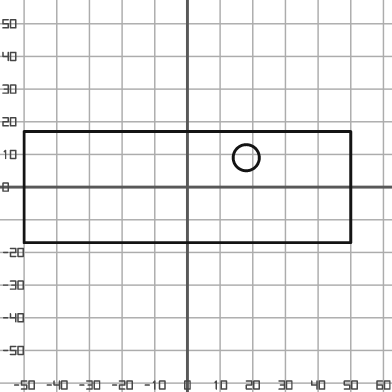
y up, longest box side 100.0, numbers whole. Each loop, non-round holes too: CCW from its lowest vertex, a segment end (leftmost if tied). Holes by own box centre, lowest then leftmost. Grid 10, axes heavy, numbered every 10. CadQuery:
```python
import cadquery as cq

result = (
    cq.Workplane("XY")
    .moveTo(-50.0, -17.0)
    .lineTo(50.0, -17.0)
    .lineTo(50.0, 17.0)
    .lineTo(-50.0, 17.0)
    .close()
    .moveTo(18.0, 9.0)
    .circle(4.0)
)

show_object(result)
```